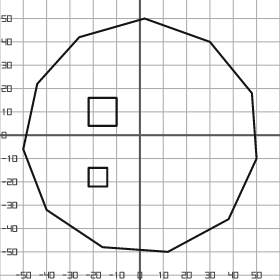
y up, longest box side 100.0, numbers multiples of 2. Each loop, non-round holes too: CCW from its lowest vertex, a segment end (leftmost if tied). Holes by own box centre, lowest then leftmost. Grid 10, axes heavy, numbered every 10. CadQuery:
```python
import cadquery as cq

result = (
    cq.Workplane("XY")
    .moveTo(12.0, -50.0)
    .lineTo(38.0, -36.0)
    .lineTo(50.0, -10.0)
    .lineTo(48.0, 18.0)
    .lineTo(30.0, 40.0)
    .lineTo(2.0, 50.0)
    .lineTo(-26.0, 42.0)
    .lineTo(-44.0, 22.0)
    .lineTo(-50.0, -6.0)
    .lineTo(-40.0, -32.0)
    .lineTo(-16.0, -48.0)
    .close()
    .moveTo(-22.0, -22.0)
    .lineTo(-14.0, -22.0)
    .lineTo(-14.0, -14.0)
    .lineTo(-22.0, -14.0)
    .close()
    .moveTo(-22.0, 4.0)
    .lineTo(-10.0, 4.0)
    .lineTo(-10.0, 16.0)
    .lineTo(-22.0, 16.0)
    .close()
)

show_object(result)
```